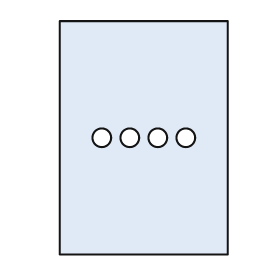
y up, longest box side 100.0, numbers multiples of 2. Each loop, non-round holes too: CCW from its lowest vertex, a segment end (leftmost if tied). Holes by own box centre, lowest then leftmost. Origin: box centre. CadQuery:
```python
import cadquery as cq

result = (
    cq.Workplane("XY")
    .moveTo(-36.0, -50.0)
    .lineTo(36.0, -50.0)
    .lineTo(36.0, 50.0)
    .lineTo(-36.0, 50.0)
    .close()
    .moveTo(-18.0, 0.0)
    .circle(4.0)
    .moveTo(-6.0, 0.0)
    .circle(4.0)
    .moveTo(6.0, 0.0)
    .circle(4.0)
    .moveTo(18.0, 0.0)
    .circle(4.0)
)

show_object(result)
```